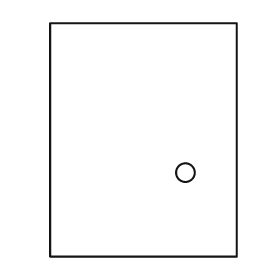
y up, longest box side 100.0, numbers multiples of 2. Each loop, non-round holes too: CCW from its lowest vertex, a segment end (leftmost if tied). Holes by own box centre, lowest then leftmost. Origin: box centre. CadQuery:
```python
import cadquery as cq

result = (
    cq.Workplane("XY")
    .moveTo(-40.0, -50.0)
    .lineTo(40.0, -50.0)
    .lineTo(40.0, 50.0)
    .lineTo(-40.0, 50.0)
    .close()
    .moveTo(18.0, -14.0)
    .circle(4.0)
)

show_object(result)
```